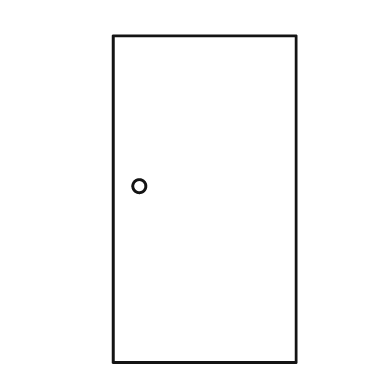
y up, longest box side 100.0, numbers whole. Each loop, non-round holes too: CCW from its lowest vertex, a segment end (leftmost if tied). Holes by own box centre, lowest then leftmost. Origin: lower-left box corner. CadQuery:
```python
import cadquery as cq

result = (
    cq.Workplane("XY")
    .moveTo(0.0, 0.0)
    .lineTo(56.0, 0.0)
    .lineTo(56.0, 100.0)
    .lineTo(0.0, 100.0)
    .close()
    .moveTo(8.0, 54.0)
    .circle(2.0)
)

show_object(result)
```